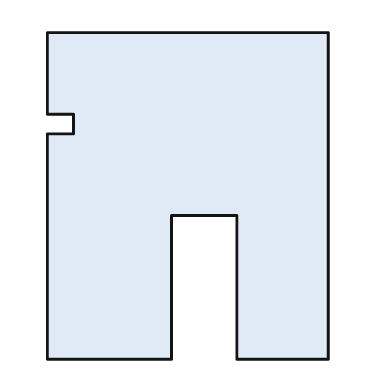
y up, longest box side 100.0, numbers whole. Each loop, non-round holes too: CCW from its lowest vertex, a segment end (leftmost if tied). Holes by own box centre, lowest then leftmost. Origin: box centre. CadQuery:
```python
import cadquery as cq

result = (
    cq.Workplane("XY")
    .moveTo(-43.0, -50.0)
    .lineTo(-5.0, -50.0)
    .lineTo(-5.0, -6.0)
    .lineTo(15.0, -6.0)
    .lineTo(15.0, -50.0)
    .lineTo(43.0, -50.0)
    .lineTo(43.0, 50.0)
    .lineTo(-43.0, 50.0)
    .lineTo(-43.0, 25.0)
    .lineTo(-35.0, 25.0)
    .lineTo(-35.0, 19.0)
    .lineTo(-43.0, 19.0)
    .close()
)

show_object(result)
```